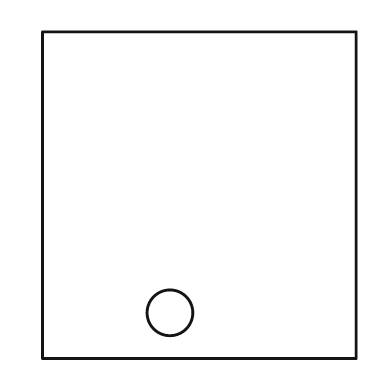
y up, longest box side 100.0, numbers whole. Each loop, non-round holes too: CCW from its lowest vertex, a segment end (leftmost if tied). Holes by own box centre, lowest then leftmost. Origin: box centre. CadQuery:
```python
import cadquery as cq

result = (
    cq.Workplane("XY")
    .moveTo(-48.0, -50.0)
    .lineTo(48.0, -50.0)
    .lineTo(48.0, 50.0)
    .lineTo(-48.0, 50.0)
    .close()
    .moveTo(-9.0, -36.0)
    .circle(7.0)
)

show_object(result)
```